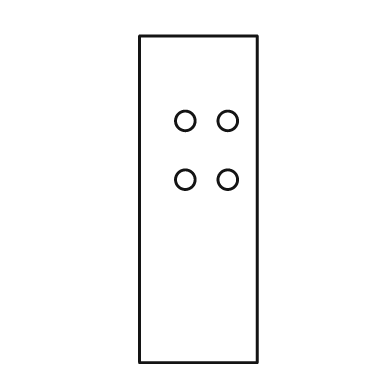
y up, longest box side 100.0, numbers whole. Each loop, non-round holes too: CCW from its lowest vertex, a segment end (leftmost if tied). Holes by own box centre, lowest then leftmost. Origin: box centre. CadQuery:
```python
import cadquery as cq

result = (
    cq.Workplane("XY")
    .moveTo(-18.0, -50.0)
    .lineTo(18.0, -50.0)
    .lineTo(18.0, 50.0)
    .lineTo(-18.0, 50.0)
    .close()
    .moveTo(-4.0, 6.0)
    .circle(3.0)
    .moveTo(9.0, 6.0)
    .circle(3.0)
    .moveTo(-4.0, 24.0)
    .circle(3.0)
    .moveTo(9.0, 24.0)
    .circle(3.0)
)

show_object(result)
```